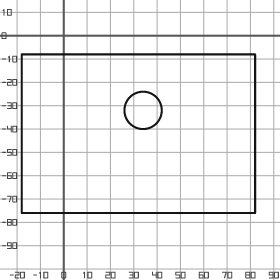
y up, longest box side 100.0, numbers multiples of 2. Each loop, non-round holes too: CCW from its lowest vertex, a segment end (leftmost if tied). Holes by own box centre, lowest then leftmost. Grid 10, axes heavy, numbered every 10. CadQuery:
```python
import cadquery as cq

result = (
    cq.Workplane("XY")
    .moveTo(-18.0, -76.0)
    .lineTo(82.0, -76.0)
    .lineTo(82.0, -8.0)
    .lineTo(-18.0, -8.0)
    .close()
    .moveTo(34.0, -32.0)
    .circle(8.0)
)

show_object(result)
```